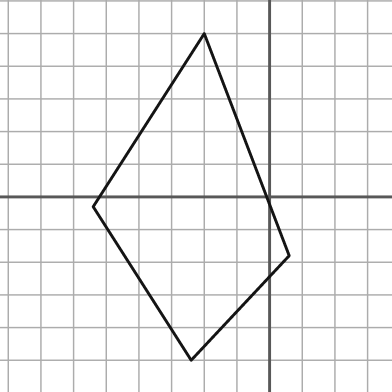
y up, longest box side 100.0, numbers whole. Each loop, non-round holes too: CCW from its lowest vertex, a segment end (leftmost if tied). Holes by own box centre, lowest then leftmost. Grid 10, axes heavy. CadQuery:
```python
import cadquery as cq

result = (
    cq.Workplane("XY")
    .moveTo(-24.0, -50.0)
    .lineTo(6.0, -18.0)
    .lineTo(-20.0, 50.0)
    .lineTo(-54.0, -3.0)
    .close()
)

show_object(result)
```